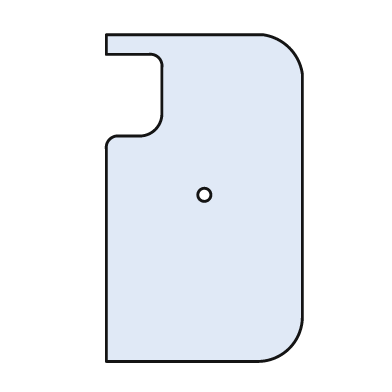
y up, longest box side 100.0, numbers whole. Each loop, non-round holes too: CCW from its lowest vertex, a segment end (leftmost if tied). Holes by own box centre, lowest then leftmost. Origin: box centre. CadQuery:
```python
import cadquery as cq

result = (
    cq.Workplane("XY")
    .moveTo(-30.0, -50.0)
    .lineTo(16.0, -50.0)
    .threePointArc((26.0, -46.0), (30.0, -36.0))
    .lineTo(30.0, 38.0)
    .threePointArc((26.0, 46.0), (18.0, 50.0))
    .lineTo(-30.0, 50.0)
    .lineTo(-30.0, 44.0)
    .lineTo(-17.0, 44.0)
    .threePointArc((-14.0, 43.0), (-13.0, 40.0))
    .lineTo(-13.0, 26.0)
    .threePointArc((-15.0, 21.0), (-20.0, 19.0))
    .lineTo(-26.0, 19.0)
    .threePointArc((-29.0, 18.0), (-30.0, 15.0))
    .close()
    .moveTo(0.0, 1.0)
    .circle(2.0)
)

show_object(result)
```